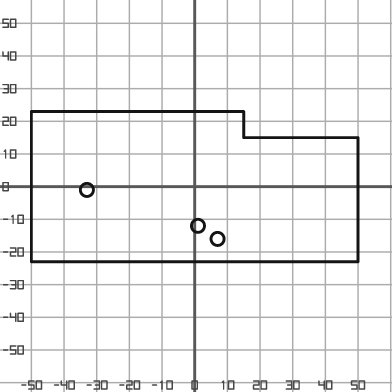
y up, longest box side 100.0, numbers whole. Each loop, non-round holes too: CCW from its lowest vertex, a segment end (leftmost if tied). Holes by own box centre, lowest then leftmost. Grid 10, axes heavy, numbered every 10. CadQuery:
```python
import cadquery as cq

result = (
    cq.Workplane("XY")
    .moveTo(-50.0, -23.0)
    .lineTo(50.0, -23.0)
    .lineTo(50.0, 15.0)
    .lineTo(15.0, 15.0)
    .lineTo(15.0, 23.0)
    .lineTo(-50.0, 23.0)
    .close()
    .moveTo(7.0, -16.0)
    .circle(2.0)
    .moveTo(1.0, -12.0)
    .circle(2.0)
    .moveTo(-33.0, -1.0)
    .circle(2.0)
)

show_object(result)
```